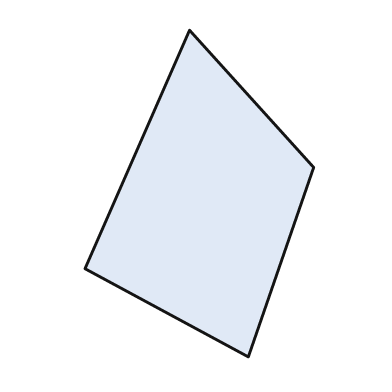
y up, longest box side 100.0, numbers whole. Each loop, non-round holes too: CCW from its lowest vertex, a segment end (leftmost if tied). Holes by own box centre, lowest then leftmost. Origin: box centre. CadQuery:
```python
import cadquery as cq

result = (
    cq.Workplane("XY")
    .moveTo(15.0, -50.0)
    .lineTo(35.0, 8.0)
    .lineTo(-3.0, 50.0)
    .lineTo(-35.0, -23.0)
    .close()
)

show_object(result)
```